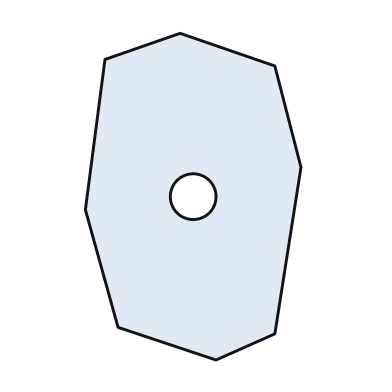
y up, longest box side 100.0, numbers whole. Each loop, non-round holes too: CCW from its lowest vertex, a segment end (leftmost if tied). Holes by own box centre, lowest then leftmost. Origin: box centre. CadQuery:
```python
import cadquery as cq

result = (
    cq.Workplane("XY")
    .moveTo(7.0, -50.0)
    .lineTo(25.0, -42.0)
    .lineTo(33.0, 9.0)
    .lineTo(25.0, 40.0)
    .lineTo(-4.0, 50.0)
    .lineTo(-27.0, 42.0)
    .lineTo(-33.0, -4.0)
    .lineTo(-23.0, -40.0)
    .close()
    .moveTo(0.0, 0.0)
    .circle(7.0)
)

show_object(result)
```